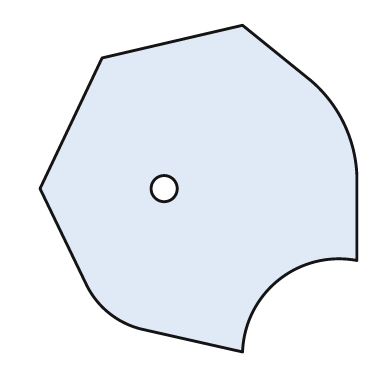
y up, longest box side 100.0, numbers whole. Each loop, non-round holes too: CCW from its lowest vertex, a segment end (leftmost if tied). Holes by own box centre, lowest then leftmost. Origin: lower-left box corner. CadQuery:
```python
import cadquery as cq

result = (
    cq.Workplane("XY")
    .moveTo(62.0, 0.0)
    .threePointArc((73.0, 22.0), (97.0, 28.0))
    .lineTo(97.0, 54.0)
    .threePointArc((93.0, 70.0), (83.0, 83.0))
    .lineTo(62.0, 100.0)
    .lineTo(19.0, 90.0)
    .lineTo(0.0, 50.0)
    .lineTo(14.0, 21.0)
    .threePointArc((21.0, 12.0), (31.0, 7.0))
    .close()
    .moveTo(38.0, 50.0)
    .circle(4.0)
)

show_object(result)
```